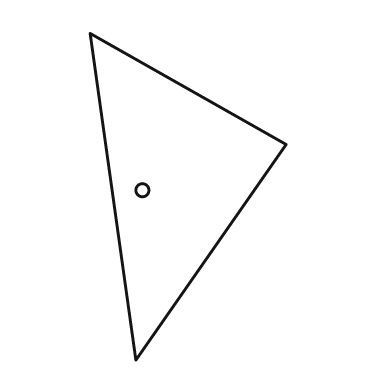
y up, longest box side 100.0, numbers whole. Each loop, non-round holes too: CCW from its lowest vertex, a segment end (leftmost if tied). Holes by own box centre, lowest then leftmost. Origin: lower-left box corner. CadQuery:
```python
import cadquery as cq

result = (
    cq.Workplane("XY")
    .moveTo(14.0, 0.0)
    .lineTo(60.0, 66.0)
    .lineTo(0.0, 100.0)
    .close()
    .moveTo(16.0, 52.0)
    .circle(2.0)
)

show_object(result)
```